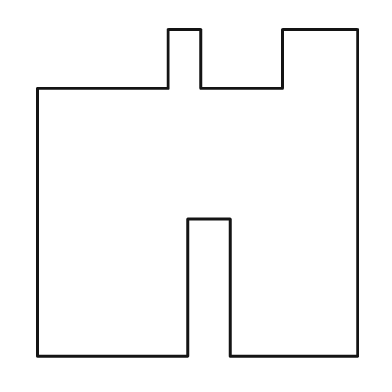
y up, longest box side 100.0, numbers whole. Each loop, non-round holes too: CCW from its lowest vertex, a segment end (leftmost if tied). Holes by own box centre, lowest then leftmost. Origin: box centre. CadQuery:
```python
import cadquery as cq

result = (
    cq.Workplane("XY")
    .moveTo(-49.0, -50.0)
    .lineTo(-3.0, -50.0)
    .lineTo(-3.0, -8.0)
    .lineTo(10.0, -8.0)
    .lineTo(10.0, -50.0)
    .lineTo(49.0, -50.0)
    .lineTo(49.0, 50.0)
    .lineTo(26.0, 50.0)
    .lineTo(26.0, 32.0)
    .lineTo(1.0, 32.0)
    .lineTo(1.0, 50.0)
    .lineTo(-9.0, 50.0)
    .lineTo(-9.0, 32.0)
    .lineTo(-49.0, 32.0)
    .close()
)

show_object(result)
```